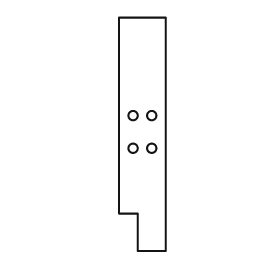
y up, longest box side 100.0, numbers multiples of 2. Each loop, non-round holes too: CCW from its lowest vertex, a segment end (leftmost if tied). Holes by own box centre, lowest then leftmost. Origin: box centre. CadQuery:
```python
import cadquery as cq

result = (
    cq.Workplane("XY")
    .moveTo(-2.0, -50.0)
    .lineTo(10.0, -50.0)
    .lineTo(10.0, 50.0)
    .lineTo(-10.0, 50.0)
    .lineTo(-10.0, -34.0)
    .lineTo(-2.0, -34.0)
    .close()
    .moveTo(-4.0, -6.0)
    .circle(2.0)
    .moveTo(4.0, -6.0)
    .circle(2.0)
    .moveTo(-4.0, 8.0)
    .circle(2.0)
    .moveTo(4.0, 8.0)
    .circle(2.0)
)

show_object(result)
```